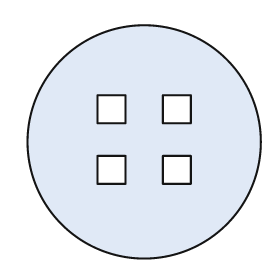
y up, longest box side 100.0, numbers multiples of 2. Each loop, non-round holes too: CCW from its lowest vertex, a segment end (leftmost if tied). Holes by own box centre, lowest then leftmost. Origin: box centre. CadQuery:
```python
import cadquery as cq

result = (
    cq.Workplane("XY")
    .moveTo(0.0, 0.0)
    .circle(50.0)
    .moveTo(-20.0, -18.0)
    .lineTo(-8.0, -18.0)
    .lineTo(-8.0, -6.0)
    .lineTo(-20.0, -6.0)
    .close()
    .moveTo(8.0, -18.0)
    .lineTo(20.0, -18.0)
    .lineTo(20.0, -6.0)
    .lineTo(8.0, -6.0)
    .close()
    .moveTo(-20.0, 8.0)
    .lineTo(-8.0, 8.0)
    .lineTo(-8.0, 20.0)
    .lineTo(-20.0, 20.0)
    .close()
    .moveTo(8.0, 8.0)
    .lineTo(20.0, 8.0)
    .lineTo(20.0, 20.0)
    .lineTo(8.0, 20.0)
    .close()
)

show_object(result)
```